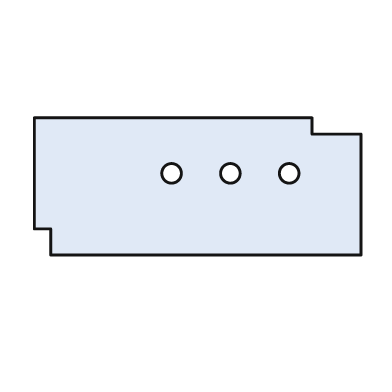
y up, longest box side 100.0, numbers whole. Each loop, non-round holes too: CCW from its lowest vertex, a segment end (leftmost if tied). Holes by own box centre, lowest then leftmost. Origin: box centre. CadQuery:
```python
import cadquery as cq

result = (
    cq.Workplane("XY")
    .moveTo(-45.0, -21.0)
    .lineTo(50.0, -21.0)
    .lineTo(50.0, 16.0)
    .lineTo(35.0, 16.0)
    .lineTo(35.0, 21.0)
    .lineTo(-50.0, 21.0)
    .lineTo(-50.0, -13.0)
    .lineTo(-45.0, -13.0)
    .close()
    .moveTo(-8.0, 4.0)
    .circle(3.0)
    .moveTo(10.0, 4.0)
    .circle(3.0)
    .moveTo(28.0, 4.0)
    .circle(3.0)
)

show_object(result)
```